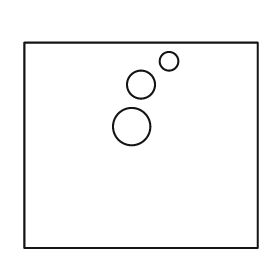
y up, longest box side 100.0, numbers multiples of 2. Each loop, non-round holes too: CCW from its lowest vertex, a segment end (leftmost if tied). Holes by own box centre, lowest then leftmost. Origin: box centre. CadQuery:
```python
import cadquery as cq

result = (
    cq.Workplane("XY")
    .moveTo(-50.0, -44.0)
    .lineTo(50.0, -44.0)
    .lineTo(50.0, 44.0)
    .lineTo(-50.0, 44.0)
    .close()
    .moveTo(-4.0, 8.0)
    .circle(8.0)
    .moveTo(0.0, 26.0)
    .circle(6.0)
    .moveTo(12.0, 36.0)
    .circle(4.0)
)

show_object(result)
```